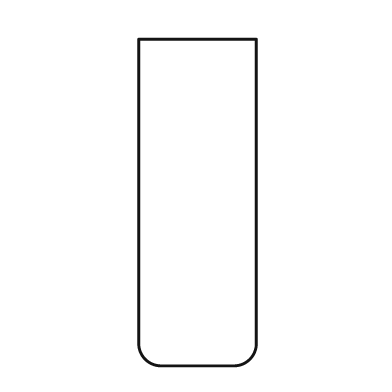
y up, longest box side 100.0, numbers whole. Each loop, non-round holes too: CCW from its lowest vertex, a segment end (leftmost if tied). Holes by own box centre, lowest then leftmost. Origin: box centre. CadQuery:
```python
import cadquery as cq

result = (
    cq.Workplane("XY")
    .moveTo(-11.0, -50.0)
    .lineTo(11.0, -50.0)
    .threePointArc((16.0, -48.0), (18.0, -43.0))
    .lineTo(18.0, 50.0)
    .lineTo(-18.0, 50.0)
    .lineTo(-18.0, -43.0)
    .threePointArc((-16.0, -48.0), (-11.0, -50.0))
    .close()
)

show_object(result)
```